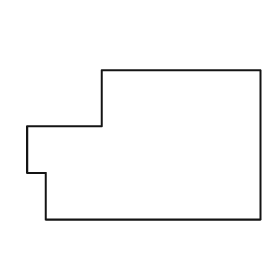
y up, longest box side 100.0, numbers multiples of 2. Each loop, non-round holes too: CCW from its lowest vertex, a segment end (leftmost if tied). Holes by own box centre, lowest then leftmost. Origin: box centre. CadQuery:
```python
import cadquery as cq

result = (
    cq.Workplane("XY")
    .moveTo(-42.0, -32.0)
    .lineTo(50.0, -32.0)
    .lineTo(50.0, 32.0)
    .lineTo(-18.0, 32.0)
    .lineTo(-18.0, 8.0)
    .lineTo(-50.0, 8.0)
    .lineTo(-50.0, -12.0)
    .lineTo(-42.0, -12.0)
    .close()
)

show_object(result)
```